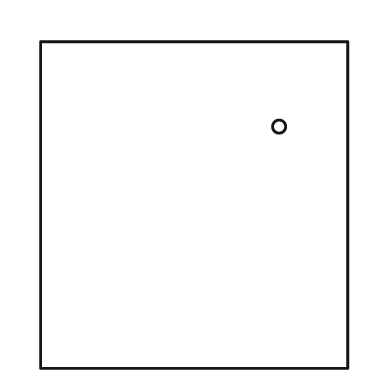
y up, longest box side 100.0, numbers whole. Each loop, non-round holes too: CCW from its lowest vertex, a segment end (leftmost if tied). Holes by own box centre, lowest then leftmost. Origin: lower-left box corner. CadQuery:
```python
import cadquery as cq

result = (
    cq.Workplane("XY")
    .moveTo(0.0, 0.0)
    .lineTo(94.0, 0.0)
    .lineTo(94.0, 100.0)
    .lineTo(0.0, 100.0)
    .close()
    .moveTo(73.0, 74.0)
    .circle(2.0)
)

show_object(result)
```